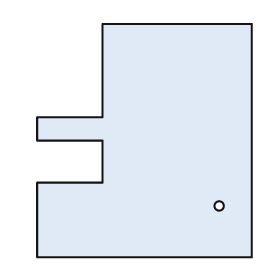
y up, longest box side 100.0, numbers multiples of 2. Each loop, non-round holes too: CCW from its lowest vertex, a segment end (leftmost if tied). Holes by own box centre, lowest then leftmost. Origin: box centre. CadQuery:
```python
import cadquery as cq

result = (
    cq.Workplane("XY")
    .moveTo(-46.0, -50.0)
    .lineTo(46.0, -50.0)
    .lineTo(46.0, 50.0)
    .lineTo(-18.0, 50.0)
    .lineTo(-18.0, 10.0)
    .lineTo(-46.0, 10.0)
    .lineTo(-46.0, 0.0)
    .lineTo(-18.0, 0.0)
    .lineTo(-18.0, -18.0)
    .lineTo(-46.0, -18.0)
    .close()
    .moveTo(32.0, -28.0)
    .circle(2.0)
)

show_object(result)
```